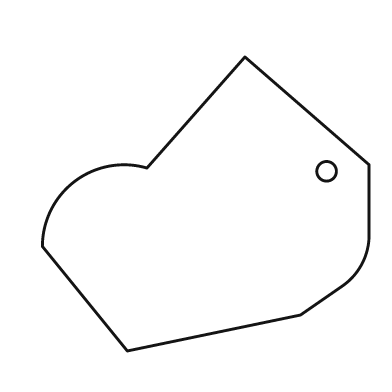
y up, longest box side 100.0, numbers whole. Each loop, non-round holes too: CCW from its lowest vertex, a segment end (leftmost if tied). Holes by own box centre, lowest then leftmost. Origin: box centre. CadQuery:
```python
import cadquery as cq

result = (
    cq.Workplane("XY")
    .moveTo(-24.0, -45.0)
    .lineTo(29.0, -34.0)
    .lineTo(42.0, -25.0)
    .threePointArc((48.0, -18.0), (50.0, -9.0))
    .lineTo(50.0, 12.0)
    .lineTo(12.0, 45.0)
    .lineTo(-18.0, 11.0)
    .threePointArc((-40.0, 7.0), (-50.0, -13.0))
    .close()
    .moveTo(37.0, 10.0)
    .circle(3.0)
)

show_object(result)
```